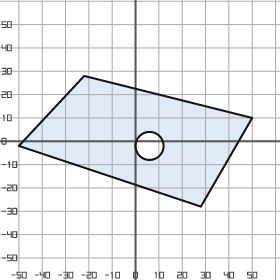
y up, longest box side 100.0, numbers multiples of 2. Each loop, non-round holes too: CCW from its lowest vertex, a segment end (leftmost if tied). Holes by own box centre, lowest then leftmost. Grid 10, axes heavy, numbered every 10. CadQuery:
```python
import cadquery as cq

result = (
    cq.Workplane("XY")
    .moveTo(28.0, -28.0)
    .lineTo(50.0, 10.0)
    .lineTo(-22.0, 28.0)
    .lineTo(-50.0, -2.0)
    .close()
    .moveTo(6.0, -2.0)
    .circle(6.0)
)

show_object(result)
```